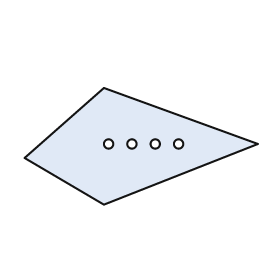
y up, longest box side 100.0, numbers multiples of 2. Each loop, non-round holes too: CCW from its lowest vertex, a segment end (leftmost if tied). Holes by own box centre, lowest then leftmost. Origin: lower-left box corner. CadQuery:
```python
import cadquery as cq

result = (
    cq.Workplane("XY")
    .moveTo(34.0, 0.0)
    .lineTo(100.0, 26.0)
    .lineTo(34.0, 50.0)
    .lineTo(0.0, 20.0)
    .close()
    .moveTo(36.0, 26.0)
    .circle(2.0)
    .moveTo(46.0, 26.0)
    .circle(2.0)
    .moveTo(56.0, 26.0)
    .circle(2.0)
    .moveTo(66.0, 26.0)
    .circle(2.0)
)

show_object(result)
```